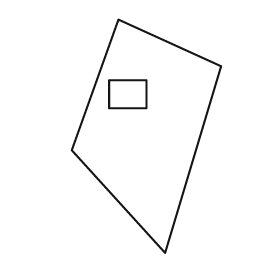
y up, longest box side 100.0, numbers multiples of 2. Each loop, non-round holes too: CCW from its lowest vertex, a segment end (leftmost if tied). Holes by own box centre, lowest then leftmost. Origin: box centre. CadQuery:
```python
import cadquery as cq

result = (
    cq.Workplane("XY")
    .moveTo(8.0, -50.0)
    .lineTo(32.0, 30.0)
    .lineTo(-12.0, 50.0)
    .lineTo(-32.0, -6.0)
    .close()
    .moveTo(-16.0, 12.0)
    .lineTo(0.0, 12.0)
    .lineTo(0.0, 24.0)
    .lineTo(-16.0, 24.0)
    .close()
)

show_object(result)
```